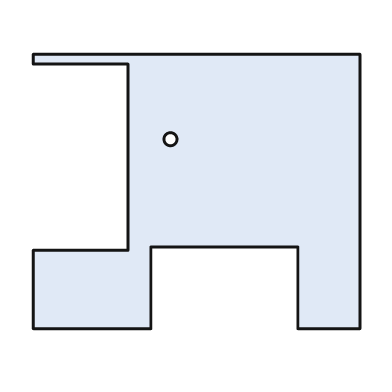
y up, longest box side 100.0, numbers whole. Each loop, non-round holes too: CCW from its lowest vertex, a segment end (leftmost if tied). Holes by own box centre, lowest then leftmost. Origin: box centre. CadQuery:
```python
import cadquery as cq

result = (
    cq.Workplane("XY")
    .moveTo(-50.0, -42.0)
    .lineTo(-14.0, -42.0)
    .lineTo(-14.0, -17.0)
    .lineTo(31.0, -17.0)
    .lineTo(31.0, -42.0)
    .lineTo(50.0, -42.0)
    .lineTo(50.0, 42.0)
    .lineTo(-50.0, 42.0)
    .lineTo(-50.0, 39.0)
    .lineTo(-21.0, 39.0)
    .lineTo(-21.0, -18.0)
    .lineTo(-50.0, -18.0)
    .close()
    .moveTo(-8.0, 16.0)
    .circle(2.0)
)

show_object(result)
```